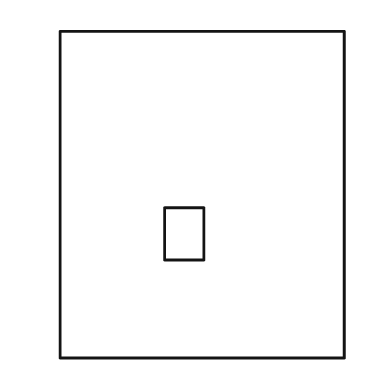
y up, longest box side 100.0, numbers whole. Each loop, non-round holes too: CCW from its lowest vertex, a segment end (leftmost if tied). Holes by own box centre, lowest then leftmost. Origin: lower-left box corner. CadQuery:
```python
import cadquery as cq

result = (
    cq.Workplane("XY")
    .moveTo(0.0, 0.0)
    .lineTo(87.0, 0.0)
    .lineTo(87.0, 100.0)
    .lineTo(0.0, 100.0)
    .close()
    .moveTo(32.0, 30.0)
    .lineTo(44.0, 30.0)
    .lineTo(44.0, 46.0)
    .lineTo(32.0, 46.0)
    .close()
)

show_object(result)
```